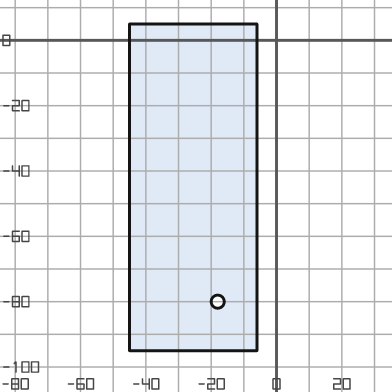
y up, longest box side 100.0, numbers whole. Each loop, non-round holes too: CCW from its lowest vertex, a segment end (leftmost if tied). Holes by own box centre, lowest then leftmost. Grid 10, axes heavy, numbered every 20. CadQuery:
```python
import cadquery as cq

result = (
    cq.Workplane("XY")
    .moveTo(-45.0, -95.0)
    .lineTo(-6.0, -95.0)
    .lineTo(-6.0, 5.0)
    .lineTo(-45.0, 5.0)
    .close()
    .moveTo(-18.0, -80.0)
    .circle(2.0)
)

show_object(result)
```